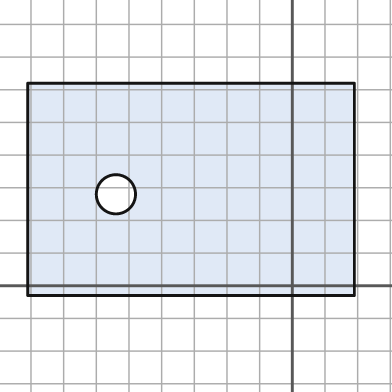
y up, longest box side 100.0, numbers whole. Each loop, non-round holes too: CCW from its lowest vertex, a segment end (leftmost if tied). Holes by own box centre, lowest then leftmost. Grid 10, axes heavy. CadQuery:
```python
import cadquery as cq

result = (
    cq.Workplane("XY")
    .moveTo(-81.0, -3.0)
    .lineTo(19.0, -3.0)
    .lineTo(19.0, 62.0)
    .lineTo(-81.0, 62.0)
    .close()
    .moveTo(-54.0, 28.0)
    .circle(6.0)
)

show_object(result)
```